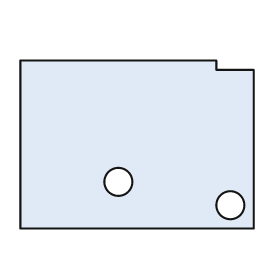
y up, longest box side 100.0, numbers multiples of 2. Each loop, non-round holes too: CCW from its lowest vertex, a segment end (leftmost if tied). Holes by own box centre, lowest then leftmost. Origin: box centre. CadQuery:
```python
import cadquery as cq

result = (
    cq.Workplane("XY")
    .moveTo(-50.0, -36.0)
    .lineTo(50.0, -36.0)
    .lineTo(50.0, 32.0)
    .lineTo(34.0, 32.0)
    .lineTo(34.0, 36.0)
    .lineTo(-50.0, 36.0)
    .close()
    .moveTo(40.0, -26.0)
    .circle(6.0)
    .moveTo(-8.0, -16.0)
    .circle(6.0)
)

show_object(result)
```